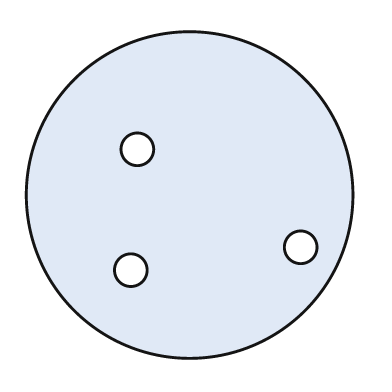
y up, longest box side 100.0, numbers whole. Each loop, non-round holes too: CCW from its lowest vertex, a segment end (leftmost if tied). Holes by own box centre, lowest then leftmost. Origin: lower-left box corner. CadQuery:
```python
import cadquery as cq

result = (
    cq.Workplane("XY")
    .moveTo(50.0, 50.0)
    .circle(50.0)
    .moveTo(32.0, 27.0)
    .circle(5.0)
    .moveTo(84.0, 34.0)
    .circle(5.0)
    .moveTo(34.0, 64.0)
    .circle(5.0)
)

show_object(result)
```